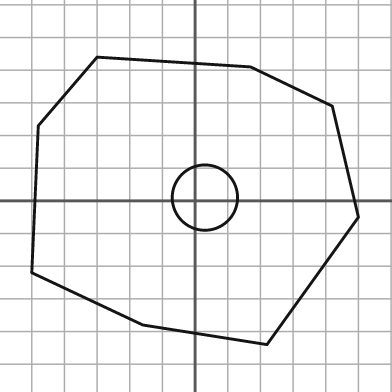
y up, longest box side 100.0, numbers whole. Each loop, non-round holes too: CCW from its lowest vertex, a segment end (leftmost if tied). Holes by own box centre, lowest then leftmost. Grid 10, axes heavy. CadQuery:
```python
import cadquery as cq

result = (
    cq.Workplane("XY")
    .moveTo(22.0, -44.0)
    .lineTo(50.0, -5.0)
    .lineTo(42.0, 29.0)
    .lineTo(17.0, 41.0)
    .lineTo(-30.0, 44.0)
    .lineTo(-48.0, 23.0)
    .lineTo(-50.0, -22.0)
    .lineTo(-16.0, -38.0)
    .close()
    .moveTo(3.0, 1.0)
    .circle(10.0)
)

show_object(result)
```